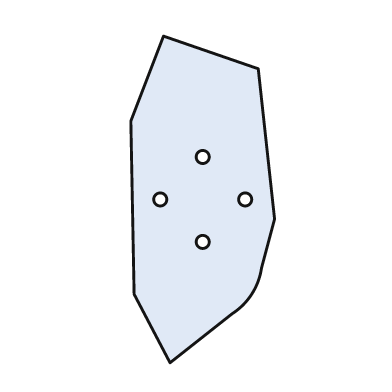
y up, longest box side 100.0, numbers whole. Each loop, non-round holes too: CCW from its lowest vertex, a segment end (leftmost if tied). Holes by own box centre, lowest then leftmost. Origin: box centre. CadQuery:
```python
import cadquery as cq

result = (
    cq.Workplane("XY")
    .moveTo(-10.0, -50.0)
    .lineTo(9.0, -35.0)
    .threePointArc((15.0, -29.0), (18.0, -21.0))
    .lineTo(22.0, -6.0)
    .lineTo(17.0, 40.0)
    .lineTo(-12.0, 50.0)
    .lineTo(-22.0, 24.0)
    .lineTo(-21.0, -29.0)
    .close()
    .moveTo(0.0, -13.0)
    .circle(2.0)
    .moveTo(-13.0, 0.0)
    .circle(2.0)
    .moveTo(13.0, 0.0)
    .circle(2.0)
    .moveTo(0.0, 13.0)
    .circle(2.0)
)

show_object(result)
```